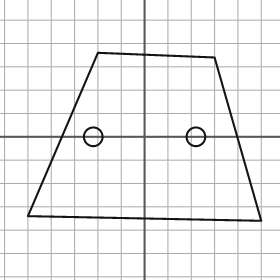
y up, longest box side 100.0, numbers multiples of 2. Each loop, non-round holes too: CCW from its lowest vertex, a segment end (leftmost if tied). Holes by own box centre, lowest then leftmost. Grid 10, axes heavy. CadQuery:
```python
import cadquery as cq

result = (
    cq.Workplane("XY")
    .moveTo(50.0, -36.0)
    .lineTo(30.0, 34.0)
    .lineTo(-20.0, 36.0)
    .lineTo(-50.0, -34.0)
    .close()
    .moveTo(-22.0, 0.0)
    .circle(4.0)
    .moveTo(22.0, 0.0)
    .circle(4.0)
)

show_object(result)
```